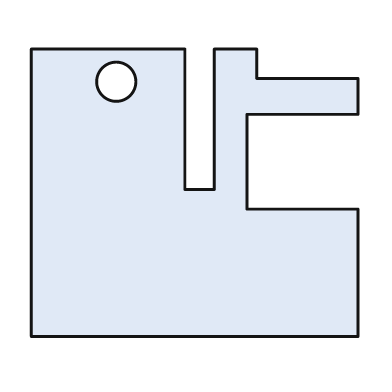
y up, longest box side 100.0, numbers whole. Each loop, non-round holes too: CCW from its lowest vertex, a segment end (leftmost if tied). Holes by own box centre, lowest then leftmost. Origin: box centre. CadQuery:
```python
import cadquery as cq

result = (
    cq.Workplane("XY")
    .moveTo(-50.0, -44.0)
    .lineTo(50.0, -44.0)
    .lineTo(50.0, -5.0)
    .lineTo(16.0, -5.0)
    .lineTo(16.0, 24.0)
    .lineTo(50.0, 24.0)
    .lineTo(50.0, 35.0)
    .lineTo(19.0, 35.0)
    .lineTo(19.0, 44.0)
    .lineTo(6.0, 44.0)
    .lineTo(6.0, 1.0)
    .lineTo(-3.0, 1.0)
    .lineTo(-3.0, 44.0)
    .lineTo(-50.0, 44.0)
    .close()
    .moveTo(-24.0, 34.0)
    .circle(6.0)
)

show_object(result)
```